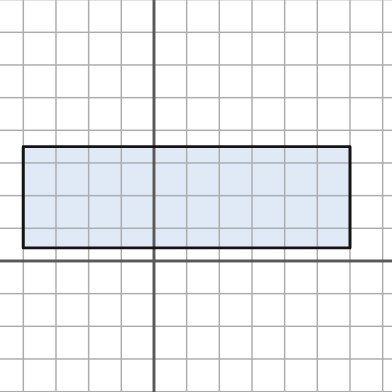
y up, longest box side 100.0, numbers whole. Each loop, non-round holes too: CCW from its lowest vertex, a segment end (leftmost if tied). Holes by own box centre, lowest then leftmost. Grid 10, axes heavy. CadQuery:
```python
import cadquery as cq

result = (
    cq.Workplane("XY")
    .moveTo(-40.0, 4.0)
    .lineTo(60.0, 4.0)
    .lineTo(60.0, 35.0)
    .lineTo(-40.0, 35.0)
    .close()
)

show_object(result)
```